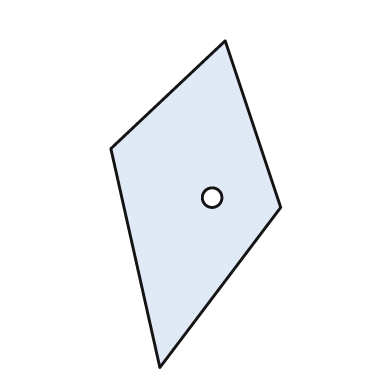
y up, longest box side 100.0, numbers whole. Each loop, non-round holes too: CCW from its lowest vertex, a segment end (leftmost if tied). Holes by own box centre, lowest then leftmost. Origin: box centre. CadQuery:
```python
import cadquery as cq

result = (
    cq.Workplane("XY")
    .moveTo(-11.0, -50.0)
    .lineTo(26.0, -1.0)
    .lineTo(9.0, 50.0)
    .lineTo(-26.0, 17.0)
    .close()
    .moveTo(5.0, 2.0)
    .circle(3.0)
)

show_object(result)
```